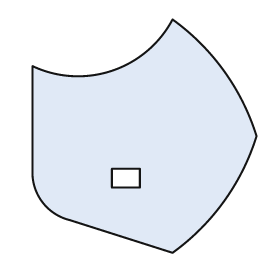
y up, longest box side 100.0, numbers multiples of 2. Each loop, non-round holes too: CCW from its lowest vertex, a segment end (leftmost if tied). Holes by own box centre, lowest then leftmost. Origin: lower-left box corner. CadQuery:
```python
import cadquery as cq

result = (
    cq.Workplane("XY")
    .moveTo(60.0, 0.0)
    .threePointArc((82.0, 22.0), (96.0, 50.0))
    .threePointArc((82.0, 78.0), (60.0, 100.0))
    .threePointArc((34.0, 78.0), (0.0, 80.0))
    .lineTo(0.0, 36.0)
    .threePointArc((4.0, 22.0), (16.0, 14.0))
    .close()
    .moveTo(34.0, 28.0)
    .lineTo(46.0, 28.0)
    .lineTo(46.0, 36.0)
    .lineTo(34.0, 36.0)
    .close()
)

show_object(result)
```